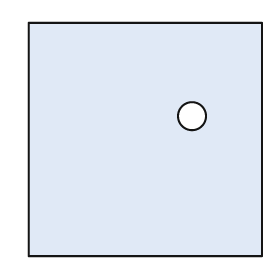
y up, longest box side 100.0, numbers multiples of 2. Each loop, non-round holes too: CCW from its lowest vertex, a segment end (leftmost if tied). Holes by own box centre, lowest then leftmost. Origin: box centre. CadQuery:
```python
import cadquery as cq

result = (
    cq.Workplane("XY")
    .moveTo(-50.0, -50.0)
    .lineTo(50.0, -50.0)
    .lineTo(50.0, 50.0)
    .lineTo(-50.0, 50.0)
    .close()
    .moveTo(20.0, 10.0)
    .circle(6.0)
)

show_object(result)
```